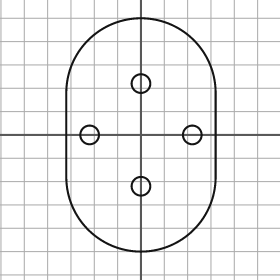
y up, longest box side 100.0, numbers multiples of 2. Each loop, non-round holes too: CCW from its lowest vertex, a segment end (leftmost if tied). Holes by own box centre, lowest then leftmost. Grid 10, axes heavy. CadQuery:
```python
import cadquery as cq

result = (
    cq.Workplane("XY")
    .moveTo(-32.0, -18.0)
    .threePointArc((0.0, -50.0), (32.0, -18.0))
    .lineTo(32.0, 18.0)
    .threePointArc((0.0, 50.0), (-32.0, 18.0))
    .close()
    .moveTo(0.0, -22.0)
    .circle(4.0)
    .moveTo(-22.0, 0.0)
    .circle(4.0)
    .moveTo(22.0, 0.0)
    .circle(4.0)
    .moveTo(0.0, 22.0)
    .circle(4.0)
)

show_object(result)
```